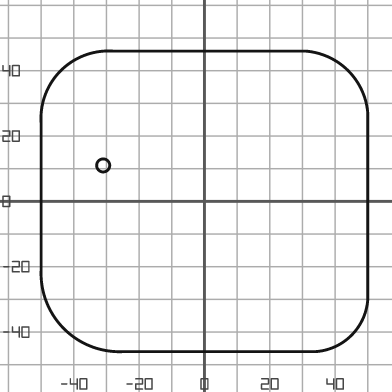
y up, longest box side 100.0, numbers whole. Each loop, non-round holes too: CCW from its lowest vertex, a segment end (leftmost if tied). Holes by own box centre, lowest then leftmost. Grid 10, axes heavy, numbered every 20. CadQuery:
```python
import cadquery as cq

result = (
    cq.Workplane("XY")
    .moveTo(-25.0, -46.0)
    .lineTo(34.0, -46.0)
    .threePointArc((45.0, -41.0), (50.0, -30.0))
    .lineTo(50.0, 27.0)
    .threePointArc((44.0, 40.0), (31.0, 46.0))
    .lineTo(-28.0, 46.0)
    .threePointArc((-44.0, 40.0), (-50.0, 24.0))
    .lineTo(-50.0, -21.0)
    .threePointArc((-43.0, -39.0), (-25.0, -46.0))
    .close()
    .moveTo(-31.0, 11.0)
    .circle(2.0)
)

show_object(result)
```